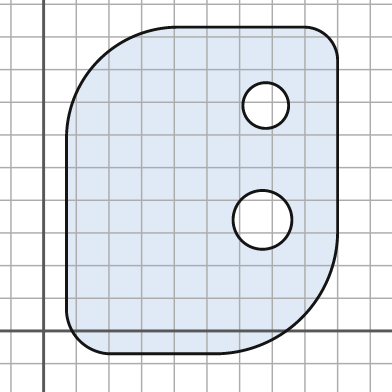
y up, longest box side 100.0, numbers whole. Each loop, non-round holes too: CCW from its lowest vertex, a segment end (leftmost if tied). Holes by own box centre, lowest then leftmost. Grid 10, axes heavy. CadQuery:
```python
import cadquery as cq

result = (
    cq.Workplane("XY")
    .moveTo(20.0, -7.0)
    .lineTo(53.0, -7.0)
    .threePointArc((79.0, 4.0), (90.0, 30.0))
    .lineTo(90.0, 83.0)
    .threePointArc((87.0, 90.0), (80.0, 93.0))
    .lineTo(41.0, 93.0)
    .threePointArc((17.0, 83.0), (7.0, 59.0))
    .lineTo(7.0, 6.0)
    .threePointArc((11.0, -3.0), (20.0, -7.0))
    .close()
    .moveTo(67.0, 34.0)
    .circle(9.0)
    .moveTo(68.0, 69.0)
    .circle(7.0)
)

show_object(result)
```